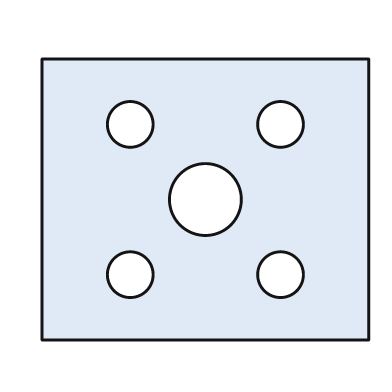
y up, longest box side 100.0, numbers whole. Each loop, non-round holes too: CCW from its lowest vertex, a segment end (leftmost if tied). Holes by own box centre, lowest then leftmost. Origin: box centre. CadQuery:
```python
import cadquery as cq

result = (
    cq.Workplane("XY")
    .moveTo(-50.0, -43.0)
    .lineTo(50.0, -43.0)
    .lineTo(50.0, 43.0)
    .lineTo(-50.0, 43.0)
    .close()
    .moveTo(-23.0, -23.0)
    .circle(7.0)
    .moveTo(23.0, -23.0)
    .circle(7.0)
    .moveTo(0.0, 0.0)
    .circle(11.0)
    .moveTo(-23.0, 23.0)
    .circle(7.0)
    .moveTo(23.0, 23.0)
    .circle(7.0)
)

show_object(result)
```